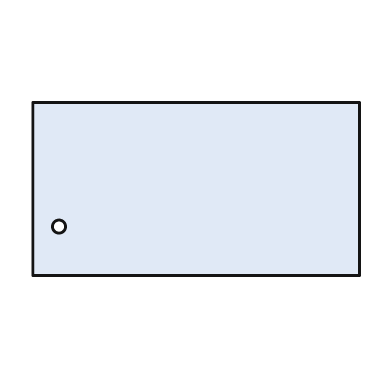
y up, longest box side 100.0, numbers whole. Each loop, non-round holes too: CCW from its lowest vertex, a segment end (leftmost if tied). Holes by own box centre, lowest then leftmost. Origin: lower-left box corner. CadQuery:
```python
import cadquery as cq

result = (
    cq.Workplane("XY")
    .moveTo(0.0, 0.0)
    .lineTo(100.0, 0.0)
    .lineTo(100.0, 53.0)
    .lineTo(0.0, 53.0)
    .close()
    .moveTo(8.0, 15.0)
    .circle(2.0)
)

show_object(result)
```